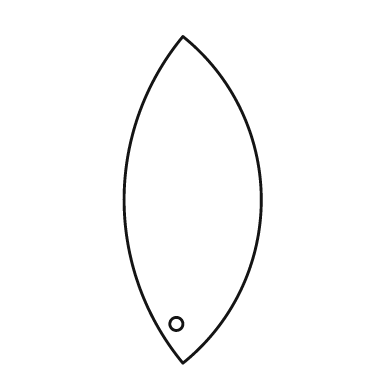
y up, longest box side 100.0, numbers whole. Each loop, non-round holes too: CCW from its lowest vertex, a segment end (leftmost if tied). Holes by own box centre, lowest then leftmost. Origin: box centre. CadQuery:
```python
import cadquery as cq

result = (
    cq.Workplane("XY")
    .moveTo(-3.0, -50.0)
    .threePointArc((21.0, 0.0), (-3.0, 50.0))
    .threePointArc((-21.0, 0.0), (-3.0, -50.0))
    .close()
    .moveTo(-5.0, -38.0)
    .circle(2.0)
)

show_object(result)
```